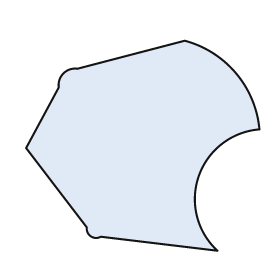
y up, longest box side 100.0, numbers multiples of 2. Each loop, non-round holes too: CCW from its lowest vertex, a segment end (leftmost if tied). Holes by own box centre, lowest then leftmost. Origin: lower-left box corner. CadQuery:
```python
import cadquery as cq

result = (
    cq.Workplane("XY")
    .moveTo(82.0, 0.0)
    .threePointArc((74.0, 32.0), (100.0, 52.0))
    .threePointArc((90.0, 76.0), (68.0, 90.0))
    .lineTo(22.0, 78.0)
    .threePointArc((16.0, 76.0), (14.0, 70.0))
    .lineTo(0.0, 44.0)
    .lineTo(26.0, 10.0)
    .threePointArc((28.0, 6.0), (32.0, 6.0))
    .close()
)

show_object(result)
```